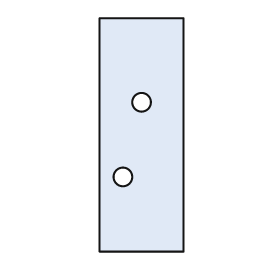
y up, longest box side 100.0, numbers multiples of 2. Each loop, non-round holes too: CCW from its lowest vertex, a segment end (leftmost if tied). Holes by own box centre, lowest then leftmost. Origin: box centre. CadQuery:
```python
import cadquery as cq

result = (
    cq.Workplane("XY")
    .moveTo(-18.0, -50.0)
    .lineTo(18.0, -50.0)
    .lineTo(18.0, 50.0)
    .lineTo(-18.0, 50.0)
    .close()
    .moveTo(-8.0, -18.0)
    .circle(4.0)
    .moveTo(0.0, 14.0)
    .circle(4.0)
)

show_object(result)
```